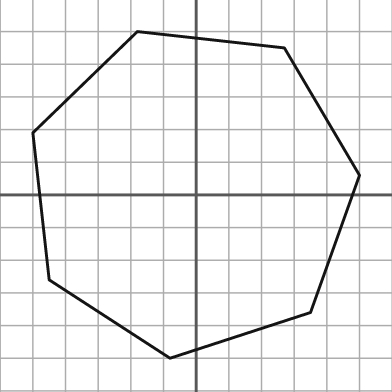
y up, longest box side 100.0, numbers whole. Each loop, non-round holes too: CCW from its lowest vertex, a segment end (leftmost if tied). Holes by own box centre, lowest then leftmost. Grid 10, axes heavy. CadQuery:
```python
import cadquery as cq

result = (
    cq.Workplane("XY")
    .moveTo(-8.0, -50.0)
    .lineTo(35.0, -36.0)
    .lineTo(50.0, 6.0)
    .lineTo(27.0, 45.0)
    .lineTo(-18.0, 50.0)
    .lineTo(-50.0, 19.0)
    .lineTo(-45.0, -26.0)
    .close()
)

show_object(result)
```